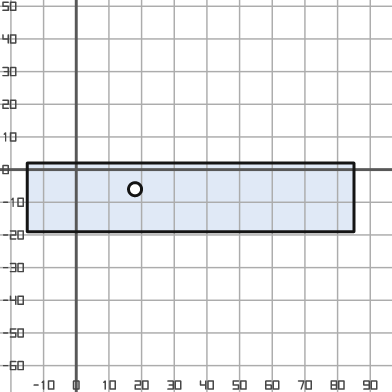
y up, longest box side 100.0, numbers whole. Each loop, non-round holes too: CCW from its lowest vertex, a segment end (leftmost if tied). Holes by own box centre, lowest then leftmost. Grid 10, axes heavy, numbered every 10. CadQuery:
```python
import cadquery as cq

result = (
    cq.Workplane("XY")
    .moveTo(-15.0, -19.0)
    .lineTo(85.0, -19.0)
    .lineTo(85.0, 2.0)
    .lineTo(-15.0, 2.0)
    .close()
    .moveTo(18.0, -6.0)
    .circle(2.0)
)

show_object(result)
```